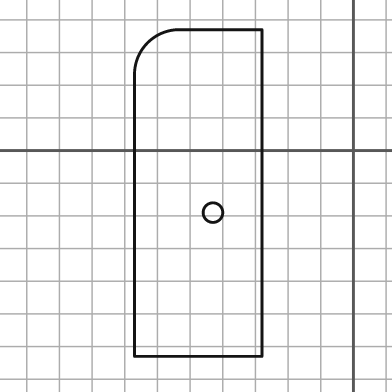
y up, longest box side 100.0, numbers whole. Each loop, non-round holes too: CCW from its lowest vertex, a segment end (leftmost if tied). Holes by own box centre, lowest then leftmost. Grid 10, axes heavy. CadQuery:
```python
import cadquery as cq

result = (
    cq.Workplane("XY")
    .moveTo(-67.0, -63.0)
    .lineTo(-28.0, -63.0)
    .lineTo(-28.0, 37.0)
    .lineTo(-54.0, 37.0)
    .threePointArc((-63.0, 33.0), (-67.0, 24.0))
    .close()
    .moveTo(-43.0, -19.0)
    .circle(3.0)
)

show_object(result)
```